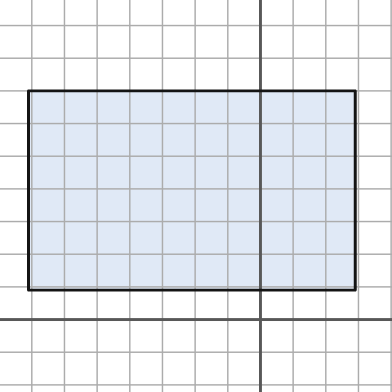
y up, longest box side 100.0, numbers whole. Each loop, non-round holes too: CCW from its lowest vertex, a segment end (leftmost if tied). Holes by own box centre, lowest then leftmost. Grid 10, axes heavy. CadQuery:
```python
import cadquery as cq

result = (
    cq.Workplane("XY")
    .moveTo(-71.0, 9.0)
    .lineTo(29.0, 9.0)
    .lineTo(29.0, 70.0)
    .lineTo(-71.0, 70.0)
    .close()
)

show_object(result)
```